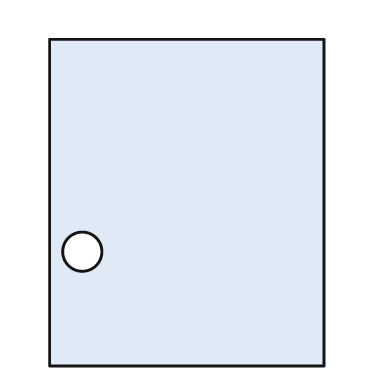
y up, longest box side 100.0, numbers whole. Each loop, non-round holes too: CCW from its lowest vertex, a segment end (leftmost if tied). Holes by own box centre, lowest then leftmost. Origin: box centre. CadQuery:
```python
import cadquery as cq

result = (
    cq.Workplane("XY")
    .moveTo(-42.0, -50.0)
    .lineTo(42.0, -50.0)
    .lineTo(42.0, 50.0)
    .lineTo(-42.0, 50.0)
    .close()
    .moveTo(-32.0, -15.0)
    .circle(6.0)
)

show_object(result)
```